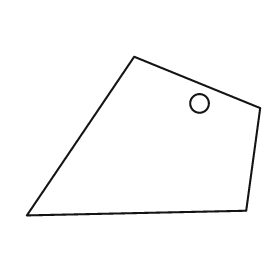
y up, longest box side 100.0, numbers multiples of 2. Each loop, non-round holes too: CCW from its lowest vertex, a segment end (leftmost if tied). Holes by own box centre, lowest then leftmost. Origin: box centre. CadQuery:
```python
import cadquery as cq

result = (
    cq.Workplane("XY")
    .moveTo(-50.0, -34.0)
    .lineTo(44.0, -32.0)
    .lineTo(50.0, 12.0)
    .lineTo(-4.0, 34.0)
    .close()
    .moveTo(24.0, 14.0)
    .circle(4.0)
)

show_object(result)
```